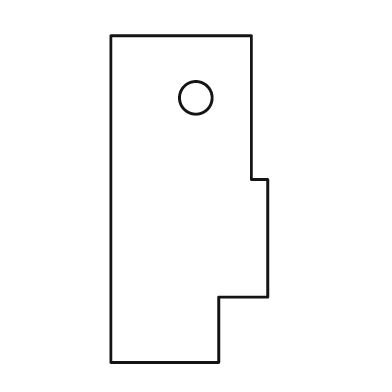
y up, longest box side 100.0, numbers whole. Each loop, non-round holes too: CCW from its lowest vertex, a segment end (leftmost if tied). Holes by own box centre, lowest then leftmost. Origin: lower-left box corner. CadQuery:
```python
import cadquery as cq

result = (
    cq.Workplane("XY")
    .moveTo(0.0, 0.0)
    .lineTo(33.0, 0.0)
    .lineTo(33.0, 20.0)
    .lineTo(48.0, 20.0)
    .lineTo(48.0, 56.0)
    .lineTo(43.0, 56.0)
    .lineTo(43.0, 100.0)
    .lineTo(0.0, 100.0)
    .close()
    .moveTo(26.0, 81.0)
    .circle(5.0)
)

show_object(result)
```